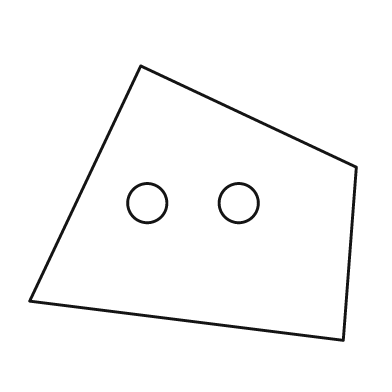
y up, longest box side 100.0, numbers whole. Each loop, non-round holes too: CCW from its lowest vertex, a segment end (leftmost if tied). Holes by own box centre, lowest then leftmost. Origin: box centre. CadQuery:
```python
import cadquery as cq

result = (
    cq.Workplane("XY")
    .moveTo(46.0, -42.0)
    .lineTo(50.0, 11.0)
    .lineTo(-16.0, 42.0)
    .lineTo(-50.0, -30.0)
    .close()
    .moveTo(-14.0, 0.0)
    .circle(6.0)
    .moveTo(14.0, 0.0)
    .circle(6.0)
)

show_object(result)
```